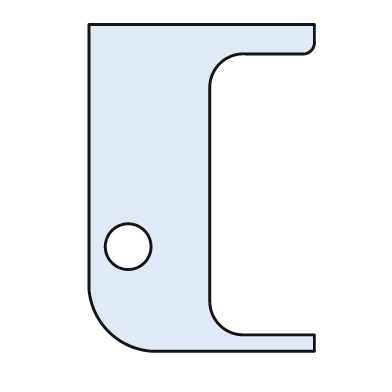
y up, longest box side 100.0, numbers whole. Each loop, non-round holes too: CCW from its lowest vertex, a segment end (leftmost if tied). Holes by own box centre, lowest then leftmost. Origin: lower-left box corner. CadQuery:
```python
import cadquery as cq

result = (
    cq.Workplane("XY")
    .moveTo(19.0, 0.0)
    .lineTo(69.0, 0.0)
    .lineTo(69.0, 5.0)
    .lineTo(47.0, 5.0)
    .threePointArc((40.0, 8.0), (37.0, 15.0))
    .lineTo(37.0, 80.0)
    .threePointArc((40.0, 88.0), (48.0, 91.0))
    .lineTo(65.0, 91.0)
    .threePointArc((68.0, 92.0), (69.0, 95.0))
    .lineTo(69.0, 100.0)
    .lineTo(0.0, 100.0)
    .lineTo(0.0, 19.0)
    .threePointArc((6.0, 6.0), (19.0, 0.0))
    .close()
    .moveTo(12.0, 32.0)
    .circle(7.0)
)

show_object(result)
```